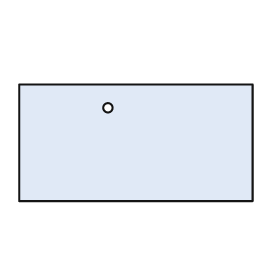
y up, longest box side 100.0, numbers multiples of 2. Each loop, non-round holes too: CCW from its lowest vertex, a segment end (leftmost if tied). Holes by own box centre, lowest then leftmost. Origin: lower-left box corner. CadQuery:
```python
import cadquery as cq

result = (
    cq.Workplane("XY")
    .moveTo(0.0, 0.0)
    .lineTo(100.0, 0.0)
    .lineTo(100.0, 50.0)
    .lineTo(0.0, 50.0)
    .close()
    .moveTo(38.0, 40.0)
    .circle(2.0)
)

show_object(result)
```